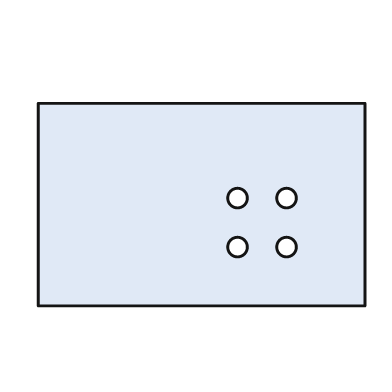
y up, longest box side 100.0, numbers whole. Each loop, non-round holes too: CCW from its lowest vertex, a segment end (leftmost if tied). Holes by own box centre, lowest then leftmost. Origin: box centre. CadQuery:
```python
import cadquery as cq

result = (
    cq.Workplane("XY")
    .moveTo(-50.0, -31.0)
    .lineTo(50.0, -31.0)
    .lineTo(50.0, 31.0)
    .lineTo(-50.0, 31.0)
    .close()
    .moveTo(11.0, -13.0)
    .circle(3.0)
    .moveTo(26.0, -13.0)
    .circle(3.0)
    .moveTo(11.0, 2.0)
    .circle(3.0)
    .moveTo(26.0, 2.0)
    .circle(3.0)
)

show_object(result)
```